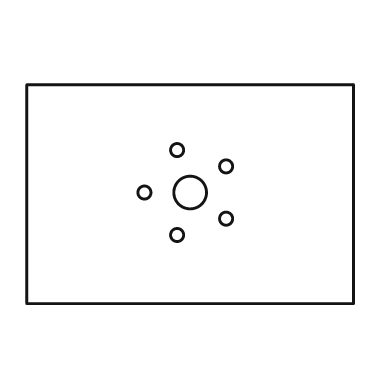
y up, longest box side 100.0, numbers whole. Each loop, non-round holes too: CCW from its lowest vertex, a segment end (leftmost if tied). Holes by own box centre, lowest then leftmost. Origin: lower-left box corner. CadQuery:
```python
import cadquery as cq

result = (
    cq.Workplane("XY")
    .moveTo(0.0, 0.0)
    .lineTo(100.0, 0.0)
    .lineTo(100.0, 67.0)
    .lineTo(0.0, 67.0)
    .close()
    .moveTo(46.0, 21.0)
    .circle(2.0)
    .moveTo(61.0, 26.0)
    .circle(2.0)
    .moveTo(36.0, 34.0)
    .circle(2.0)
    .moveTo(50.0, 34.0)
    .circle(5.0)
    .moveTo(61.0, 42.0)
    .circle(2.0)
    .moveTo(46.0, 47.0)
    .circle(2.0)
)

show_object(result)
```